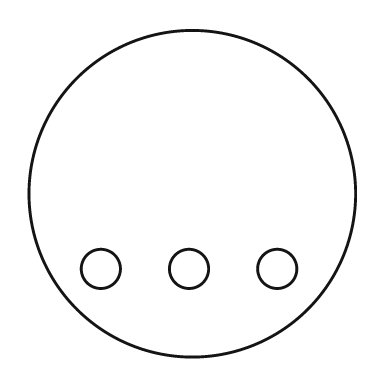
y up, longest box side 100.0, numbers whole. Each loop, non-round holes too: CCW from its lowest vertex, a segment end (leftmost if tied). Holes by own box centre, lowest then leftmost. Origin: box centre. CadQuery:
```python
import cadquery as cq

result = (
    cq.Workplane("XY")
    .moveTo(0.0, 0.0)
    .circle(50.0)
    .moveTo(-28.0, -23.0)
    .circle(6.0)
    .moveTo(-1.0, -23.0)
    .circle(6.0)
    .moveTo(26.0, -23.0)
    .circle(6.0)
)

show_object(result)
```